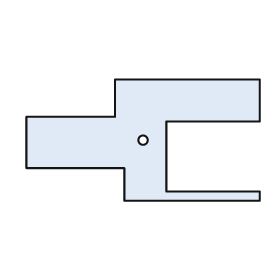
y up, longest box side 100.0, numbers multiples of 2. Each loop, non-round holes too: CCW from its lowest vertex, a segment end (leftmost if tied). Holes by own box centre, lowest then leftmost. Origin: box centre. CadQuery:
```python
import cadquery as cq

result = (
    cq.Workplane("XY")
    .moveTo(-8.0, -26.0)
    .lineTo(50.0, -26.0)
    .lineTo(50.0, -22.0)
    .lineTo(10.0, -22.0)
    .lineTo(10.0, 8.0)
    .lineTo(50.0, 8.0)
    .lineTo(50.0, 26.0)
    .lineTo(-12.0, 26.0)
    .lineTo(-12.0, 10.0)
    .lineTo(-50.0, 10.0)
    .lineTo(-50.0, -12.0)
    .lineTo(-8.0, -12.0)
    .close()
    .moveTo(0.0, 0.0)
    .circle(2.0)
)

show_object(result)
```